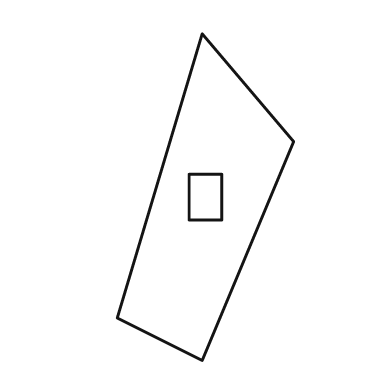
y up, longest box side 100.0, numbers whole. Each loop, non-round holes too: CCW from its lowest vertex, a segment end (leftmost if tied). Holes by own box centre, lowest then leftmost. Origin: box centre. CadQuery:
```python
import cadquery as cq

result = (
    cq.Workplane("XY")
    .moveTo(-1.0, -50.0)
    .lineTo(27.0, 17.0)
    .lineTo(-1.0, 50.0)
    .lineTo(-27.0, -37.0)
    .close()
    .moveTo(-5.0, -7.0)
    .lineTo(5.0, -7.0)
    .lineTo(5.0, 7.0)
    .lineTo(-5.0, 7.0)
    .close()
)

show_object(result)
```